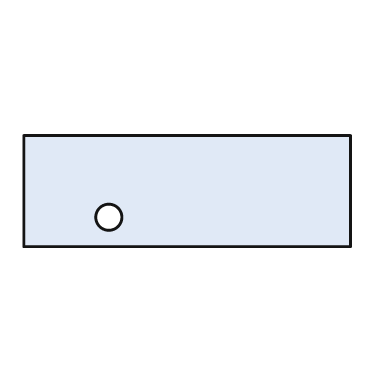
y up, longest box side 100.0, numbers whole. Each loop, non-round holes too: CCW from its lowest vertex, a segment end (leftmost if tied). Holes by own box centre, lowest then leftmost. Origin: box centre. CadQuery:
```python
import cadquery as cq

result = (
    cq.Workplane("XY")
    .moveTo(-50.0, -17.0)
    .lineTo(50.0, -17.0)
    .lineTo(50.0, 17.0)
    .lineTo(-50.0, 17.0)
    .close()
    .moveTo(-24.0, -8.0)
    .circle(4.0)
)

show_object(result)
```